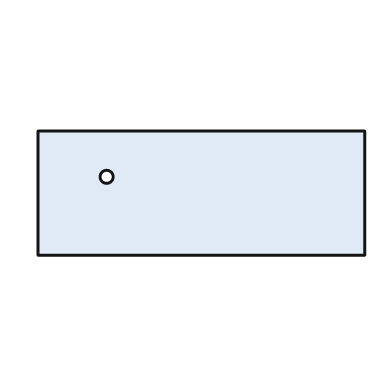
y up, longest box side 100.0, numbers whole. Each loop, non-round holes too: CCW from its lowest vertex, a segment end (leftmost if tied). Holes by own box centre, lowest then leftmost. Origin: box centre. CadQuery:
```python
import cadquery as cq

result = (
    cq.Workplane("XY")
    .moveTo(-50.0, -19.0)
    .lineTo(50.0, -19.0)
    .lineTo(50.0, 19.0)
    .lineTo(-50.0, 19.0)
    .close()
    .moveTo(-29.0, 5.0)
    .circle(2.0)
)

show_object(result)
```